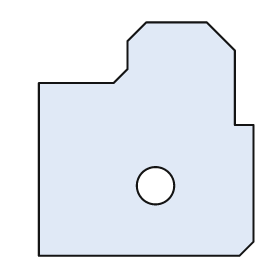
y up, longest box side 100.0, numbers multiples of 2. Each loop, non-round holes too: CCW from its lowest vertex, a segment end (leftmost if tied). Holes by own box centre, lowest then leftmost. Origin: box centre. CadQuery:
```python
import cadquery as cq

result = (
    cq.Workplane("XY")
    .moveTo(-46.0, -50.0)
    .lineTo(40.0, -50.0)
    .lineTo(46.0, -44.0)
    .lineTo(46.0, 6.0)
    .lineTo(38.0, 6.0)
    .lineTo(38.0, 38.0)
    .lineTo(26.0, 50.0)
    .lineTo(0.0, 50.0)
    .lineTo(-8.0, 42.0)
    .lineTo(-8.0, 30.0)
    .lineTo(-14.0, 24.0)
    .lineTo(-46.0, 24.0)
    .close()
    .moveTo(4.0, -20.0)
    .circle(8.0)
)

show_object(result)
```